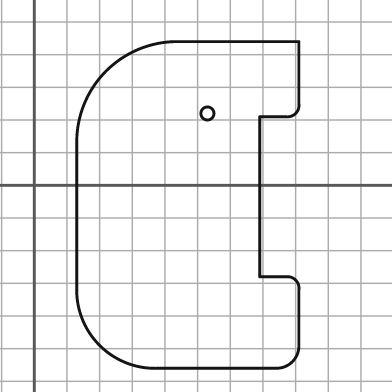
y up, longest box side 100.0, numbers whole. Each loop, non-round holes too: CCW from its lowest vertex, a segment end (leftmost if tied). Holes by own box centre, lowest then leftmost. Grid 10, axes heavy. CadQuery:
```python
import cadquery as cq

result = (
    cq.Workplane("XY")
    .moveTo(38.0, -56.0)
    .lineTo(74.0, -56.0)
    .threePointArc((79.0, -54.0), (81.0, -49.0))
    .lineTo(81.0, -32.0)
    .threePointArc((80.0, -29.0), (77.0, -28.0))
    .lineTo(69.0, -28.0)
    .lineTo(69.0, 21.0)
    .lineTo(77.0, 21.0)
    .threePointArc((80.0, 22.0), (81.0, 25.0))
    .lineTo(81.0, 44.0)
    .lineTo(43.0, 44.0)
    .threePointArc((22.0, 35.0), (13.0, 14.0))
    .lineTo(13.0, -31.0)
    .threePointArc((20.0, -49.0), (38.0, -56.0))
    .close()
    .moveTo(53.0, 22.0)
    .circle(2.0)
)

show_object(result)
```